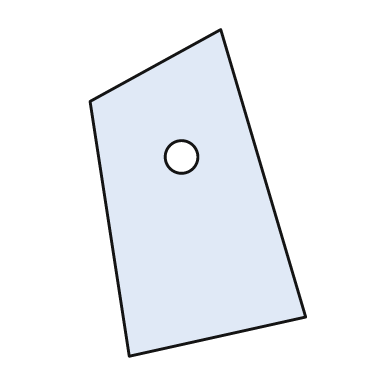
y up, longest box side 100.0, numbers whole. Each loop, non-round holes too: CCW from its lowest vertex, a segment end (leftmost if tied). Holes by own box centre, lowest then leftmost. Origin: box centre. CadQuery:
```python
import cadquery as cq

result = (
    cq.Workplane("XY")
    .moveTo(-21.0, -50.0)
    .lineTo(33.0, -38.0)
    .lineTo(7.0, 50.0)
    .lineTo(-33.0, 28.0)
    .close()
    .moveTo(-5.0, 11.0)
    .circle(5.0)
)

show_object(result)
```